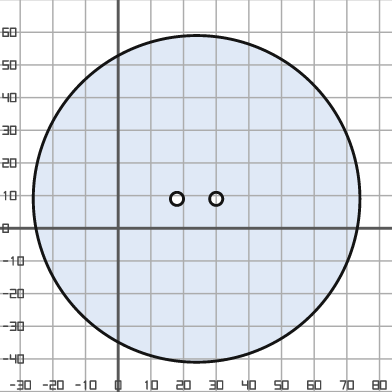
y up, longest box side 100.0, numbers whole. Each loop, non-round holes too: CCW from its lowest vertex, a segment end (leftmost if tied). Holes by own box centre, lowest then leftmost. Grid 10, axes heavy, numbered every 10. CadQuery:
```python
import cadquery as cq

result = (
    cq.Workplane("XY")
    .moveTo(24.0, 9.0)
    .circle(50.0)
    .moveTo(18.0, 9.0)
    .circle(2.0)
    .moveTo(30.0, 9.0)
    .circle(2.0)
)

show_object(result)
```